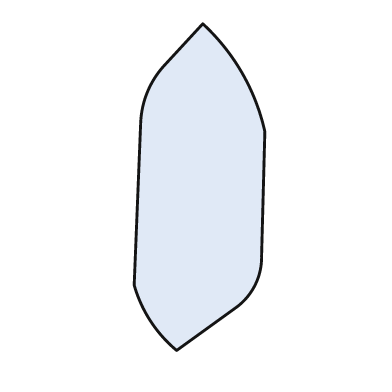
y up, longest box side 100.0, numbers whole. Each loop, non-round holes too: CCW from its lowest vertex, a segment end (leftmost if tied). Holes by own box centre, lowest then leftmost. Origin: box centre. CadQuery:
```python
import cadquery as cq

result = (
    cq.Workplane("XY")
    .moveTo(-7.0, -50.0)
    .lineTo(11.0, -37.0)
    .threePointArc((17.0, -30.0), (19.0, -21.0))
    .lineTo(20.0, 17.0)
    .threePointArc((13.0, 35.0), (1.0, 50.0))
    .lineTo(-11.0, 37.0)
    .threePointArc((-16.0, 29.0), (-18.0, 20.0))
    .lineTo(-20.0, -30.0)
    .threePointArc((-15.0, -41.0), (-7.0, -50.0))
    .close()
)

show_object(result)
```